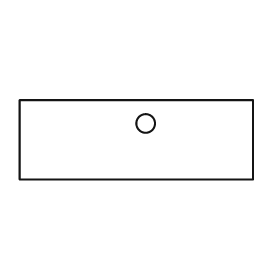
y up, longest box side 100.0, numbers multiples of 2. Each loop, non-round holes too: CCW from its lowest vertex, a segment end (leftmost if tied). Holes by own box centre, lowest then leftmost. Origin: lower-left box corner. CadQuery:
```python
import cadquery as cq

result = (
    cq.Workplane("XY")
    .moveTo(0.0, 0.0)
    .lineTo(100.0, 0.0)
    .lineTo(100.0, 34.0)
    .lineTo(0.0, 34.0)
    .close()
    .moveTo(54.0, 24.0)
    .circle(4.0)
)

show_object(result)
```